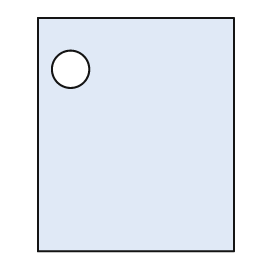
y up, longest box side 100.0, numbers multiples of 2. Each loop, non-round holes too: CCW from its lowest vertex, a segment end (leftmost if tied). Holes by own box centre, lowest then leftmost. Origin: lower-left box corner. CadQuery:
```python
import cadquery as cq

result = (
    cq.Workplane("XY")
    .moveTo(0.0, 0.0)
    .lineTo(84.0, 0.0)
    .lineTo(84.0, 100.0)
    .lineTo(0.0, 100.0)
    .close()
    .moveTo(14.0, 78.0)
    .circle(8.0)
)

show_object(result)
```